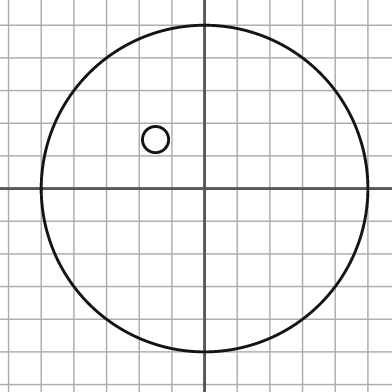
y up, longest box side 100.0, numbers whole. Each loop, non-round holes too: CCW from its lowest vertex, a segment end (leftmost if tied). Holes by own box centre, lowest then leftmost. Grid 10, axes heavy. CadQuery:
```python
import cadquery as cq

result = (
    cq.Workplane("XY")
    .moveTo(0.0, 0.0)
    .circle(50.0)
    .moveTo(-15.0, 15.0)
    .circle(4.0)
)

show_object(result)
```